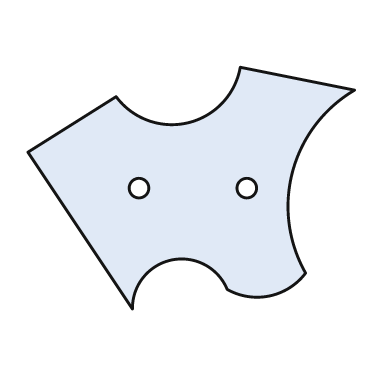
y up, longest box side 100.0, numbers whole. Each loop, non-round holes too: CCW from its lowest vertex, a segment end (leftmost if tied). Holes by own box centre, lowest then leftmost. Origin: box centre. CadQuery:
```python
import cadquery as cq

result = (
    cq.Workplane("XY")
    .moveTo(-18.0, -37.0)
    .threePointArc((-6.0, -22.0), (11.0, -31.0))
    .threePointArc((24.0, -33.0), (35.0, -26.0))
    .threePointArc((31.0, 5.0), (50.0, 30.0))
    .lineTo(15.0, 37.0)
    .threePointArc((-1.0, 20.0), (-23.0, 28.0))
    .lineTo(-50.0, 11.0)
    .close()
    .moveTo(-16.0, 0.0)
    .circle(3.0)
    .moveTo(17.0, 0.0)
    .circle(3.0)
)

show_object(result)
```